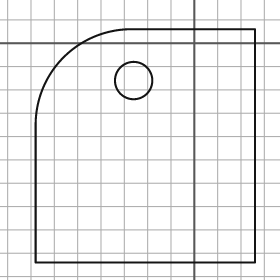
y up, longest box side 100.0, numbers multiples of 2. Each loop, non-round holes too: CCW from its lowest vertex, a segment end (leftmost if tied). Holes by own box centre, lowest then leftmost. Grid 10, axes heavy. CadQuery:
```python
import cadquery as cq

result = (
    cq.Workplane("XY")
    .moveTo(-68.0, -94.0)
    .lineTo(26.0, -94.0)
    .lineTo(26.0, 6.0)
    .lineTo(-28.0, 6.0)
    .threePointArc((-56.0, -6.0), (-68.0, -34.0))
    .close()
    .moveTo(-26.0, -16.0)
    .circle(8.0)
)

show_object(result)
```